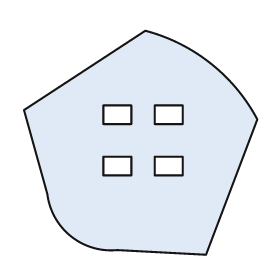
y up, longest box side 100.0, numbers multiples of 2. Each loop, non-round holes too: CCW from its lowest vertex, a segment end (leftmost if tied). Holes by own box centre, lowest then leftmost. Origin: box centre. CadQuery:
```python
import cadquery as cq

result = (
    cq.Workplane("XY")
    .moveTo(28.0, -48.0)
    .lineTo(50.0, 10.0)
    .threePointArc((30.0, 34.0), (2.0, 48.0))
    .lineTo(-50.0, 14.0)
    .lineTo(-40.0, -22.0)
    .threePointArc((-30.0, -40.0), (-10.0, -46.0))
    .close()
    .moveTo(-16.0, -14.0)
    .lineTo(-4.0, -14.0)
    .lineTo(-4.0, -6.0)
    .lineTo(-16.0, -6.0)
    .close()
    .moveTo(6.0, -14.0)
    .lineTo(18.0, -14.0)
    .lineTo(18.0, -6.0)
    .lineTo(6.0, -6.0)
    .close()
    .moveTo(-16.0, 8.0)
    .lineTo(-4.0, 8.0)
    .lineTo(-4.0, 16.0)
    .lineTo(-16.0, 16.0)
    .close()
    .moveTo(6.0, 8.0)
    .lineTo(18.0, 8.0)
    .lineTo(18.0, 16.0)
    .lineTo(6.0, 16.0)
    .close()
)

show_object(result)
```